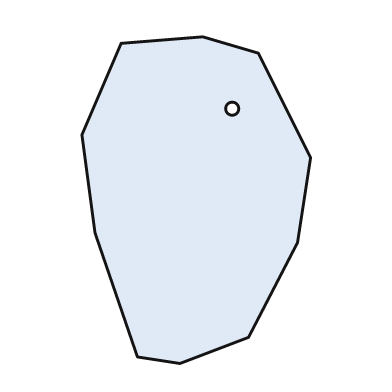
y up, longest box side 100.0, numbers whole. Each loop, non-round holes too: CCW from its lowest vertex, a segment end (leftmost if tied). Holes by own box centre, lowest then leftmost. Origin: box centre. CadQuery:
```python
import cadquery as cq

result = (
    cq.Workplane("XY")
    .moveTo(-5.0, -50.0)
    .lineTo(16.0, -42.0)
    .lineTo(31.0, -13.0)
    .lineTo(35.0, 13.0)
    .lineTo(19.0, 45.0)
    .lineTo(2.0, 50.0)
    .lineTo(-23.0, 48.0)
    .lineTo(-35.0, 20.0)
    .lineTo(-31.0, -10.0)
    .lineTo(-18.0, -48.0)
    .close()
    .moveTo(11.0, 28.0)
    .circle(2.0)
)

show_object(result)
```